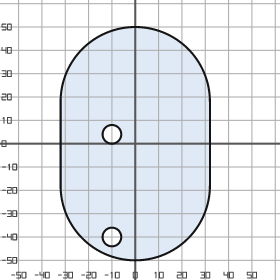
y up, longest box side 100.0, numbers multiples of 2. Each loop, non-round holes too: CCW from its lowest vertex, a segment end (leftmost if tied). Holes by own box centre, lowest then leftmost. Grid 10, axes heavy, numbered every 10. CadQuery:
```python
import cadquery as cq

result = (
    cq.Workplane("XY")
    .moveTo(-32.0, -18.0)
    .threePointArc((0.0, -50.0), (32.0, -18.0))
    .lineTo(32.0, 18.0)
    .threePointArc((0.0, 50.0), (-32.0, 18.0))
    .close()
    .moveTo(-10.0, -40.0)
    .circle(4.0)
    .moveTo(-10.0, 4.0)
    .circle(4.0)
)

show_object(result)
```